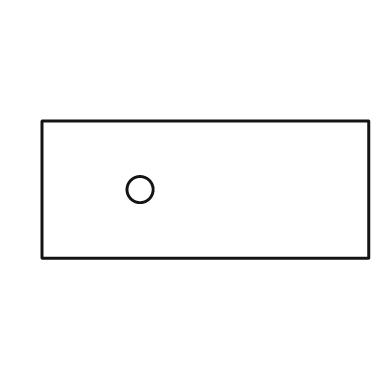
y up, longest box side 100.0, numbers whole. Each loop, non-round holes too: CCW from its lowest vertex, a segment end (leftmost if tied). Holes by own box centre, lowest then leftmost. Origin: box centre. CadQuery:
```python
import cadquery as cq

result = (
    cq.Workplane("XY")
    .moveTo(-50.0, -21.0)
    .lineTo(50.0, -21.0)
    .lineTo(50.0, 21.0)
    .lineTo(-50.0, 21.0)
    .close()
    .moveTo(-20.0, 0.0)
    .circle(4.0)
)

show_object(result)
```